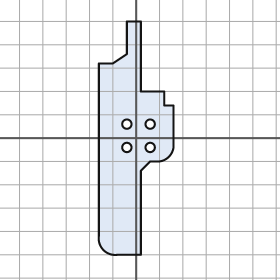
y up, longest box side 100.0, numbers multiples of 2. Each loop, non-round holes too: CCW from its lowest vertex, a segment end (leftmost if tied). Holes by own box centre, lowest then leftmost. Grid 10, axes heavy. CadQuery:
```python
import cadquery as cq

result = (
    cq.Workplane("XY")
    .moveTo(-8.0, -50.0)
    .lineTo(2.0, -50.0)
    .lineTo(2.0, -14.0)
    .lineTo(6.0, -10.0)
    .lineTo(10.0, -10.0)
    .threePointArc((14.0, -8.0), (16.0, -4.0))
    .lineTo(16.0, 14.0)
    .lineTo(12.0, 14.0)
    .lineTo(12.0, 20.0)
    .lineTo(2.0, 20.0)
    .lineTo(2.0, 50.0)
    .lineTo(-4.0, 50.0)
    .lineTo(-4.0, 36.0)
    .lineTo(-10.0, 32.0)
    .lineTo(-16.0, 32.0)
    .lineTo(-16.0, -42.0)
    .threePointArc((-14.0, -48.0), (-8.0, -50.0))
    .close()
    .moveTo(-4.0, -4.0)
    .circle(2.0)
    .moveTo(6.0, -4.0)
    .circle(2.0)
    .moveTo(-4.0, 6.0)
    .circle(2.0)
    .moveTo(6.0, 6.0)
    .circle(2.0)
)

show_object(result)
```